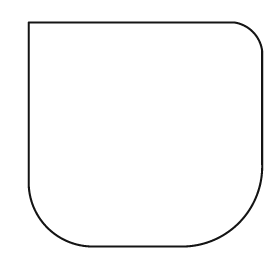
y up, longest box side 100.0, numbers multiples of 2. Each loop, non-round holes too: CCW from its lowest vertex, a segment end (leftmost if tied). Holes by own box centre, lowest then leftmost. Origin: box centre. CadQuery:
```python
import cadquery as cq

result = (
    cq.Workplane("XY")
    .moveTo(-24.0, -48.0)
    .lineTo(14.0, -48.0)
    .threePointArc((40.0, -38.0), (50.0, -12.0))
    .lineTo(50.0, 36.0)
    .threePointArc((46.0, 44.0), (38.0, 48.0))
    .lineTo(-50.0, 48.0)
    .lineTo(-50.0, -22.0)
    .threePointArc((-42.0, -40.0), (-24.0, -48.0))
    .close()
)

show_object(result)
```